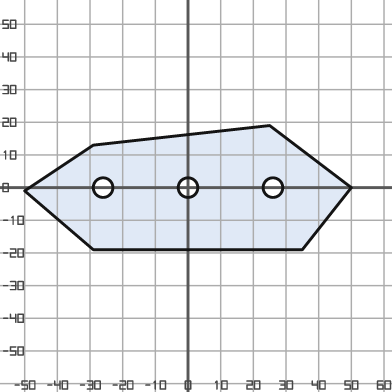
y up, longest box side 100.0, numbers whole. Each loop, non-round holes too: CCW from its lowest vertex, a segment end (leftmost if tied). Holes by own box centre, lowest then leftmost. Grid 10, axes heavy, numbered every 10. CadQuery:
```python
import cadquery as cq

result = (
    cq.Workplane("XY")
    .moveTo(-29.0, -19.0)
    .lineTo(35.0, -19.0)
    .lineTo(50.0, 0.0)
    .lineTo(25.0, 19.0)
    .lineTo(-29.0, 13.0)
    .lineTo(-50.0, -1.0)
    .close()
    .moveTo(-26.0, 0.0)
    .circle(3.0)
    .moveTo(0.0, 0.0)
    .circle(3.0)
    .moveTo(26.0, 0.0)
    .circle(3.0)
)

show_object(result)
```